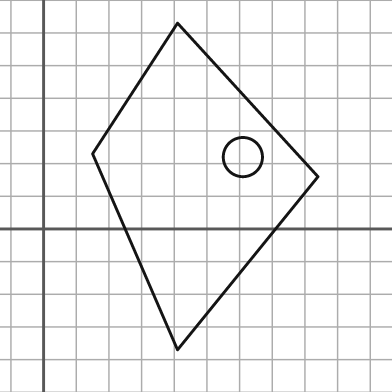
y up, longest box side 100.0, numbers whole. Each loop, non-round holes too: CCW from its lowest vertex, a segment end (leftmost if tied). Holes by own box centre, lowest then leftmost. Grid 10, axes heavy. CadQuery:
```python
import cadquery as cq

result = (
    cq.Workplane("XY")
    .moveTo(41.0, -37.0)
    .lineTo(84.0, 16.0)
    .lineTo(41.0, 63.0)
    .lineTo(15.0, 23.0)
    .close()
    .moveTo(61.0, 22.0)
    .circle(6.0)
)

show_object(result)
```